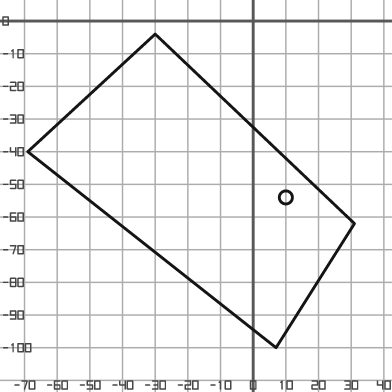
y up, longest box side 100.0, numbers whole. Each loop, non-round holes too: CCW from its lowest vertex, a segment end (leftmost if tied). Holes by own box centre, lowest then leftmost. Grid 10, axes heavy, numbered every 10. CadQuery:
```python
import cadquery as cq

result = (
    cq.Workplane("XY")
    .moveTo(7.0, -100.0)
    .lineTo(31.0, -62.0)
    .lineTo(-30.0, -4.0)
    .lineTo(-69.0, -40.0)
    .close()
    .moveTo(10.0, -54.0)
    .circle(2.0)
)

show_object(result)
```